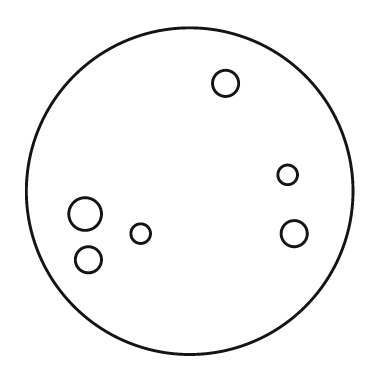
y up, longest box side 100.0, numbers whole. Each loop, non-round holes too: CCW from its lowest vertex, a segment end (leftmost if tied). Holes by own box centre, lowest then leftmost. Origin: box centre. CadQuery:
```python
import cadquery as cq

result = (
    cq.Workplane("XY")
    .moveTo(0.0, 0.0)
    .circle(50.0)
    .moveTo(-31.0, -21.0)
    .circle(4.0)
    .moveTo(-15.0, -13.0)
    .circle(3.0)
    .moveTo(32.0, -13.0)
    .circle(4.0)
    .moveTo(-32.0, -7.0)
    .circle(5.0)
    .moveTo(30.0, 5.0)
    .circle(3.0)
    .moveTo(11.0, 33.0)
    .circle(4.0)
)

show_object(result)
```